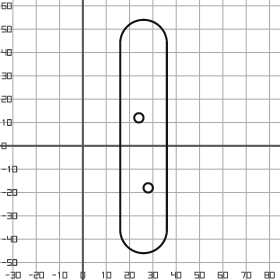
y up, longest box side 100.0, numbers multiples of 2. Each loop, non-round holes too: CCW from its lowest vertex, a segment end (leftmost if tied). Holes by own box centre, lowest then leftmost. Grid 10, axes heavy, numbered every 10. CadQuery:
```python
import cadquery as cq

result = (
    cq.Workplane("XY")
    .moveTo(16.0, -36.0)
    .threePointArc((26.0, -46.0), (36.0, -36.0))
    .lineTo(36.0, 44.0)
    .threePointArc((26.0, 54.0), (16.0, 44.0))
    .close()
    .moveTo(28.0, -18.0)
    .circle(2.0)
    .moveTo(24.0, 12.0)
    .circle(2.0)
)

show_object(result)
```